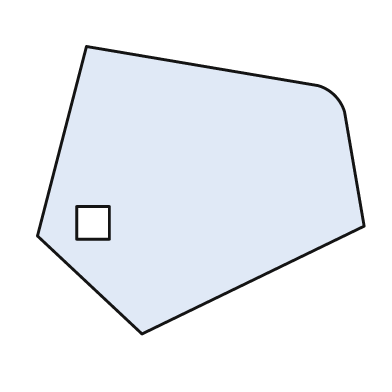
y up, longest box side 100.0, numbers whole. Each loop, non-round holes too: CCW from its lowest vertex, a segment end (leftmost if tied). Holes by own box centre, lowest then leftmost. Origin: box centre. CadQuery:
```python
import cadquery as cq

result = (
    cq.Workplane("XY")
    .moveTo(-18.0, -44.0)
    .lineTo(50.0, -11.0)
    .lineTo(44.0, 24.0)
    .threePointArc((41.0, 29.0), (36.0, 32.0))
    .lineTo(-35.0, 44.0)
    .lineTo(-50.0, -14.0)
    .close()
    .moveTo(-38.0, -15.0)
    .lineTo(-28.0, -15.0)
    .lineTo(-28.0, -5.0)
    .lineTo(-38.0, -5.0)
    .close()
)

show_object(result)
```